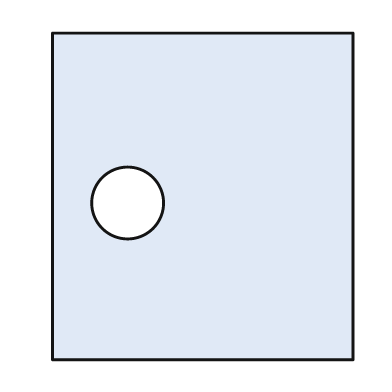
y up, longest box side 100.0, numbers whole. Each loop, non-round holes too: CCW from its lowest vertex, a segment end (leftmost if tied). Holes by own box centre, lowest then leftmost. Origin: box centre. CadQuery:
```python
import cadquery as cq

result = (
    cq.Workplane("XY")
    .moveTo(-46.0, -50.0)
    .lineTo(46.0, -50.0)
    .lineTo(46.0, 50.0)
    .lineTo(-46.0, 50.0)
    .close()
    .moveTo(-23.0, -2.0)
    .circle(11.0)
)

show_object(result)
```